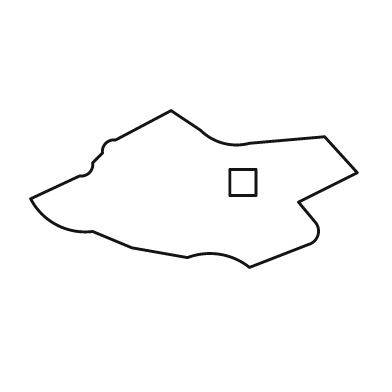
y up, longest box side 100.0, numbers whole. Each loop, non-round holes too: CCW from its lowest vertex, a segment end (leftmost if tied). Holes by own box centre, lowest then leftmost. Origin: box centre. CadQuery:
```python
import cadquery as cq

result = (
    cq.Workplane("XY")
    .moveTo(17.0, -24.0)
    .lineTo(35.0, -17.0)
    .threePointArc((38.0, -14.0), (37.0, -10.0))
    .lineTo(32.0, -4.0)
    .lineTo(50.0, 5.0)
    .lineTo(40.0, 16.0)
    .lineTo(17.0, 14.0)
    .threePointArc((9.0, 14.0), (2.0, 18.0))
    .lineTo(-7.0, 24.0)
    .lineTo(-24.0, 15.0)
    .threePointArc((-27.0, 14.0), (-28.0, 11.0))
    .lineTo(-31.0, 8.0)
    .threePointArc((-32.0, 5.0), (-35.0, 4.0))
    .lineTo(-50.0, -3.0)
    .threePointArc((-42.0, -11.0), (-31.0, -13.0))
    .lineTo(-19.0, -18.0)
    .lineTo(-2.0, -21.0)
    .threePointArc((8.0, -20.0), (17.0, -24.0))
    .close()
    .moveTo(11.0, -2.0)
    .lineTo(19.0, -2.0)
    .lineTo(19.0, 6.0)
    .lineTo(11.0, 6.0)
    .close()
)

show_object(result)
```